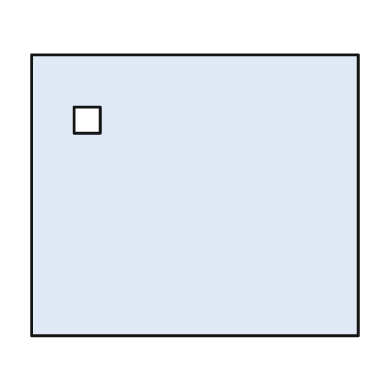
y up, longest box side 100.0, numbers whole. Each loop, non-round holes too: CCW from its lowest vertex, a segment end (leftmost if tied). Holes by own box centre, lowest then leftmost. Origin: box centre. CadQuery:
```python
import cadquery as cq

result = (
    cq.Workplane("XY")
    .moveTo(-50.0, -43.0)
    .lineTo(50.0, -43.0)
    .lineTo(50.0, 43.0)
    .lineTo(-50.0, 43.0)
    .close()
    .moveTo(-37.0, 19.0)
    .lineTo(-29.0, 19.0)
    .lineTo(-29.0, 27.0)
    .lineTo(-37.0, 27.0)
    .close()
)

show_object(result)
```